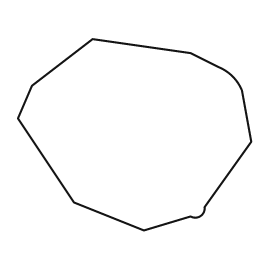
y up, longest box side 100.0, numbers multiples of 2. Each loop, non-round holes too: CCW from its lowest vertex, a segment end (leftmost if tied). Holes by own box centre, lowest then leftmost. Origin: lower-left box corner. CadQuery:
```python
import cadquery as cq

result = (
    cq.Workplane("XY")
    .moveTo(54.0, 0.0)
    .lineTo(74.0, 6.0)
    .threePointArc((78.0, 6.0), (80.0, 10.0))
    .lineTo(100.0, 38.0)
    .lineTo(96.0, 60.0)
    .threePointArc((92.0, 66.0), (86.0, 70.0))
    .lineTo(74.0, 76.0)
    .lineTo(32.0, 82.0)
    .lineTo(6.0, 62.0)
    .lineTo(0.0, 48.0)
    .lineTo(24.0, 12.0)
    .close()
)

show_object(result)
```